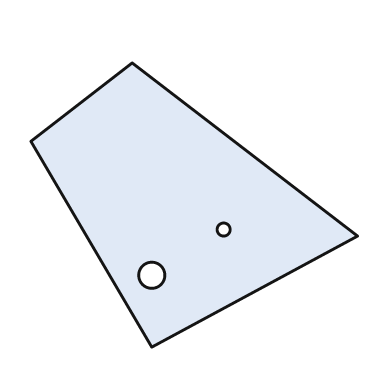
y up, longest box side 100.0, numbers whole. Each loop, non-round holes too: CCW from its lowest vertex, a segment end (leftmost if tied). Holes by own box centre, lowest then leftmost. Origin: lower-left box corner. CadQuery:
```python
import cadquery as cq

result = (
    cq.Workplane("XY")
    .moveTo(37.0, 0.0)
    .lineTo(100.0, 34.0)
    .lineTo(31.0, 87.0)
    .lineTo(0.0, 63.0)
    .close()
    .moveTo(37.0, 22.0)
    .circle(4.0)
    .moveTo(59.0, 36.0)
    .circle(2.0)
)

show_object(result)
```